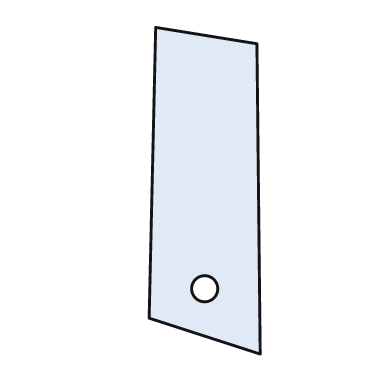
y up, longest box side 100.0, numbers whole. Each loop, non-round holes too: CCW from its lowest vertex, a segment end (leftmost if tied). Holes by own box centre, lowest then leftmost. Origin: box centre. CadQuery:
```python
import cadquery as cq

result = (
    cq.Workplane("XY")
    .moveTo(17.0, -50.0)
    .lineTo(16.0, 45.0)
    .lineTo(-15.0, 50.0)
    .lineTo(-17.0, -39.0)
    .close()
    .moveTo(0.0, -30.0)
    .circle(4.0)
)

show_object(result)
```